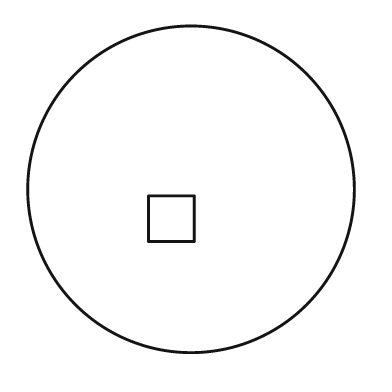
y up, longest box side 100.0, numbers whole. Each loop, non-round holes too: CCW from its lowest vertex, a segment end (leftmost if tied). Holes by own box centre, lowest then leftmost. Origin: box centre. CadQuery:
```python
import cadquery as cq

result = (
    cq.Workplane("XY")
    .moveTo(0.0, 0.0)
    .circle(50.0)
    .moveTo(-13.0, -16.0)
    .lineTo(1.0, -16.0)
    .lineTo(1.0, -2.0)
    .lineTo(-13.0, -2.0)
    .close()
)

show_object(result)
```